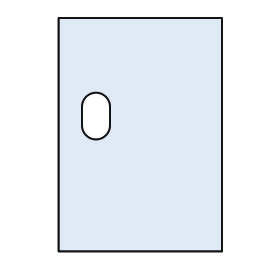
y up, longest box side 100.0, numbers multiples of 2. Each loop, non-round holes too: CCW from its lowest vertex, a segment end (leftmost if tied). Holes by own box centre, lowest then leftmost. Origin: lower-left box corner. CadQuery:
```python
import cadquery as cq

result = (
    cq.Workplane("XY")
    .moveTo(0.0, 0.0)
    .lineTo(70.0, 0.0)
    .lineTo(70.0, 100.0)
    .lineTo(0.0, 100.0)
    .close()
    .moveTo(10.0, 54.0)
    .threePointArc((16.0, 48.0), (22.0, 54.0))
    .lineTo(22.0, 62.0)
    .threePointArc((16.0, 68.0), (10.0, 62.0))
    .close()
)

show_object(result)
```